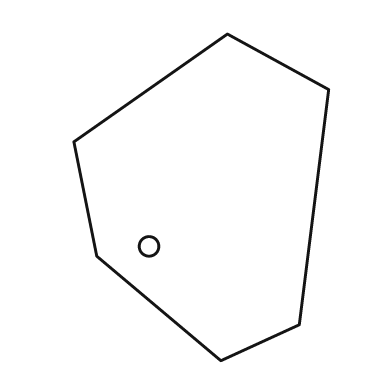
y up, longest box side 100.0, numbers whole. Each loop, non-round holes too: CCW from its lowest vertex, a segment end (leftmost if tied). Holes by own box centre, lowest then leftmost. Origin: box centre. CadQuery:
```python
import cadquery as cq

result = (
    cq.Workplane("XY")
    .moveTo(6.0, -50.0)
    .lineTo(30.0, -39.0)
    .lineTo(39.0, 33.0)
    .lineTo(8.0, 50.0)
    .lineTo(-39.0, 17.0)
    .lineTo(-32.0, -18.0)
    .close()
    .moveTo(-16.0, -15.0)
    .circle(3.0)
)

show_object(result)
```